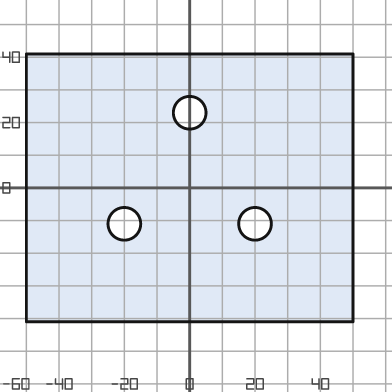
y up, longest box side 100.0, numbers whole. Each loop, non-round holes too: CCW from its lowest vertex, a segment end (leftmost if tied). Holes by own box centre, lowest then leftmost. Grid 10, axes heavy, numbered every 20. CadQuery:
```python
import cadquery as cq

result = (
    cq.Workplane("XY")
    .moveTo(-50.0, -41.0)
    .lineTo(50.0, -41.0)
    .lineTo(50.0, 41.0)
    .lineTo(-50.0, 41.0)
    .close()
    .moveTo(-20.0, -11.0)
    .circle(5.0)
    .moveTo(20.0, -11.0)
    .circle(5.0)
    .moveTo(0.0, 23.0)
    .circle(5.0)
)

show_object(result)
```